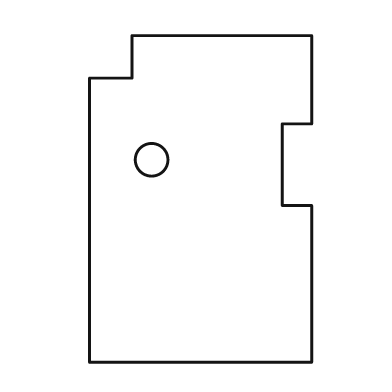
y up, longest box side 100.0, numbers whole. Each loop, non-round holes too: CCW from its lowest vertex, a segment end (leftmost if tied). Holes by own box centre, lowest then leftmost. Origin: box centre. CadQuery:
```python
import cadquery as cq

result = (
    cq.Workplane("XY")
    .moveTo(-34.0, -50.0)
    .lineTo(34.0, -50.0)
    .lineTo(34.0, -2.0)
    .lineTo(25.0, -2.0)
    .lineTo(25.0, 23.0)
    .lineTo(34.0, 23.0)
    .lineTo(34.0, 50.0)
    .lineTo(-21.0, 50.0)
    .lineTo(-21.0, 37.0)
    .lineTo(-34.0, 37.0)
    .close()
    .moveTo(-15.0, 12.0)
    .circle(5.0)
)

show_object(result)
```